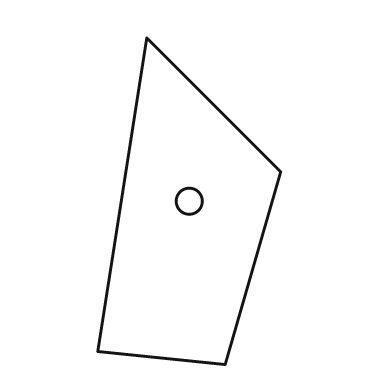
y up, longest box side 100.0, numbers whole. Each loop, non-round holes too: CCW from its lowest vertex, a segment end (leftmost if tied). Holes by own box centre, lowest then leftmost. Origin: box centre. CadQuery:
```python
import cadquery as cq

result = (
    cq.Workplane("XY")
    .moveTo(11.0, -50.0)
    .lineTo(28.0, 9.0)
    .lineTo(-13.0, 50.0)
    .lineTo(-28.0, -46.0)
    .close()
    .moveTo(0.0, 0.0)
    .circle(4.0)
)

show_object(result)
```